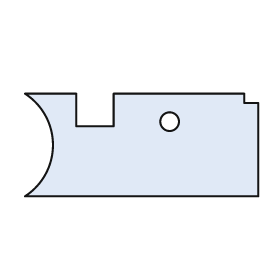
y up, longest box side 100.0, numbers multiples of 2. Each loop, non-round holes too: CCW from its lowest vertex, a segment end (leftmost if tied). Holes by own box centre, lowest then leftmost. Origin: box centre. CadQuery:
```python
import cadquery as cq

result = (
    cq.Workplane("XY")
    .moveTo(-50.0, -22.0)
    .lineTo(50.0, -22.0)
    .lineTo(50.0, 18.0)
    .lineTo(44.0, 18.0)
    .lineTo(44.0, 22.0)
    .lineTo(-12.0, 22.0)
    .lineTo(-12.0, 8.0)
    .lineTo(-28.0, 8.0)
    .lineTo(-28.0, 22.0)
    .lineTo(-50.0, 22.0)
    .threePointArc((-38.0, 0.0), (-50.0, -22.0))
    .close()
    .moveTo(12.0, 10.0)
    .circle(4.0)
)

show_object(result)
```